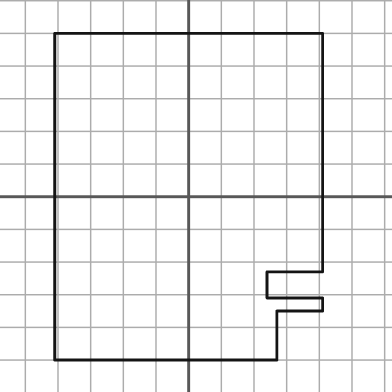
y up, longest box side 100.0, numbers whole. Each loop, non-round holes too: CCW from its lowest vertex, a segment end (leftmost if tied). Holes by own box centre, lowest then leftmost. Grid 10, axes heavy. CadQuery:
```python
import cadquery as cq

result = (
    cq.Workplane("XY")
    .moveTo(-41.0, -50.0)
    .lineTo(27.0, -50.0)
    .lineTo(27.0, -35.0)
    .lineTo(41.0, -35.0)
    .lineTo(41.0, -31.0)
    .lineTo(24.0, -31.0)
    .lineTo(24.0, -23.0)
    .lineTo(41.0, -23.0)
    .lineTo(41.0, 50.0)
    .lineTo(-41.0, 50.0)
    .close()
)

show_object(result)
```